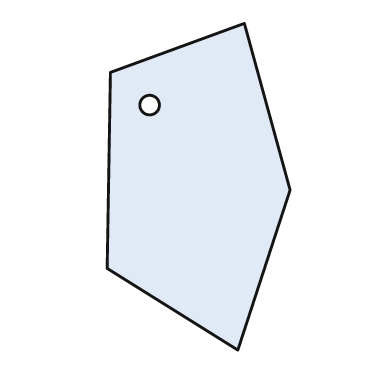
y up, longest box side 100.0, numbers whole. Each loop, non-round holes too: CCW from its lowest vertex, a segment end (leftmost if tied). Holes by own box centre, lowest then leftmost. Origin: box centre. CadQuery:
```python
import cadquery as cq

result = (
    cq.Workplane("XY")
    .moveTo(12.0, -50.0)
    .lineTo(28.0, -1.0)
    .lineTo(14.0, 50.0)
    .lineTo(-27.0, 35.0)
    .lineTo(-28.0, -25.0)
    .close()
    .moveTo(-15.0, 25.0)
    .circle(3.0)
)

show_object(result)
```